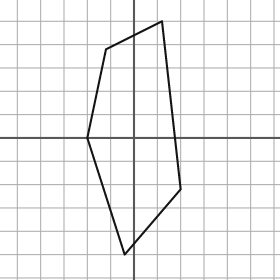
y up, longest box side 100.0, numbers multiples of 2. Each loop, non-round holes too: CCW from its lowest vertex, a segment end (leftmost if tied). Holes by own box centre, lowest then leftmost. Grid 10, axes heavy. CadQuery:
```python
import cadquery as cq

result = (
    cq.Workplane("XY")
    .moveTo(-4.0, -50.0)
    .lineTo(20.0, -22.0)
    .lineTo(12.0, 50.0)
    .lineTo(-12.0, 38.0)
    .lineTo(-20.0, 0.0)
    .close()
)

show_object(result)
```